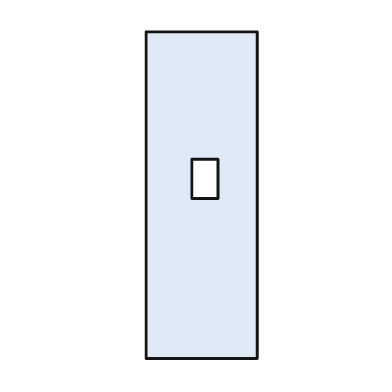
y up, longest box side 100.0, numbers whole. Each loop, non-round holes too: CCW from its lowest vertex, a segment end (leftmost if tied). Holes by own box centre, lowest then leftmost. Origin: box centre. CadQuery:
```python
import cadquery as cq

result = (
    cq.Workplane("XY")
    .moveTo(-17.0, -50.0)
    .lineTo(17.0, -50.0)
    .lineTo(17.0, 50.0)
    .lineTo(-17.0, 50.0)
    .close()
    .moveTo(-3.0, -1.0)
    .lineTo(5.0, -1.0)
    .lineTo(5.0, 11.0)
    .lineTo(-3.0, 11.0)
    .close()
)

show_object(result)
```